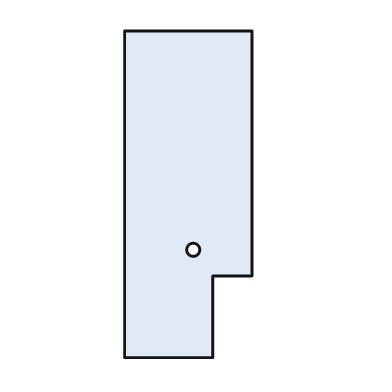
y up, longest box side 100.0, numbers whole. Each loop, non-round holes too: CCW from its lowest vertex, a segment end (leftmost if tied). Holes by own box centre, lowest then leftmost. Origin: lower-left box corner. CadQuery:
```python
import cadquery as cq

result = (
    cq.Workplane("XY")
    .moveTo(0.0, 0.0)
    .lineTo(27.0, 0.0)
    .lineTo(27.0, 25.0)
    .lineTo(39.0, 25.0)
    .lineTo(39.0, 100.0)
    .lineTo(0.0, 100.0)
    .close()
    .moveTo(21.0, 33.0)
    .circle(2.0)
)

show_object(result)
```